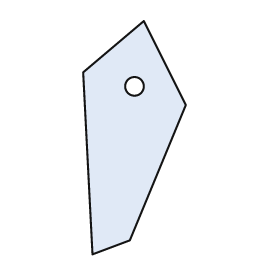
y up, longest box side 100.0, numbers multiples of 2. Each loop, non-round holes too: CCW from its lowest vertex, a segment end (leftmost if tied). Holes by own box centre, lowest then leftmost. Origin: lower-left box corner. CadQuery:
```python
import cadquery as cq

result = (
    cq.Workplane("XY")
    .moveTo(4.0, 0.0)
    .lineTo(20.0, 6.0)
    .lineTo(44.0, 64.0)
    .lineTo(26.0, 100.0)
    .lineTo(0.0, 78.0)
    .close()
    .moveTo(22.0, 72.0)
    .circle(4.0)
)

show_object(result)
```